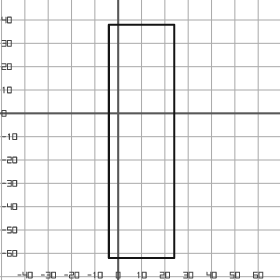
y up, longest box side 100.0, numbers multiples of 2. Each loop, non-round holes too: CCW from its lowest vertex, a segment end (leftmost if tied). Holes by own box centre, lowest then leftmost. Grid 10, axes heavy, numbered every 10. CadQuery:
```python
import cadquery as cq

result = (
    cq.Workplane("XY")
    .moveTo(-4.0, -62.0)
    .lineTo(24.0, -62.0)
    .lineTo(24.0, 38.0)
    .lineTo(-4.0, 38.0)
    .close()
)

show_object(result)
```